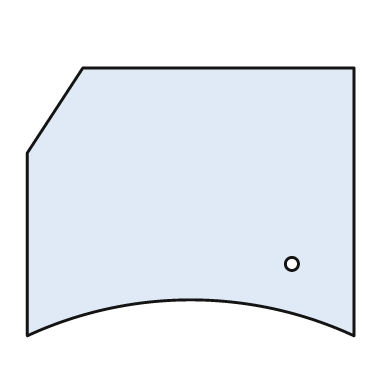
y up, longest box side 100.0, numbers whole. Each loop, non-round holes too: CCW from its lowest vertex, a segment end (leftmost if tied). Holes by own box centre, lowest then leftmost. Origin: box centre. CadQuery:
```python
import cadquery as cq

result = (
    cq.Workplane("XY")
    .moveTo(-50.0, -41.0)
    .threePointArc((0.0, -30.0), (50.0, -41.0))
    .lineTo(50.0, 41.0)
    .lineTo(-33.0, 41.0)
    .lineTo(-50.0, 15.0)
    .close()
    .moveTo(31.0, -19.0)
    .circle(2.0)
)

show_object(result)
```